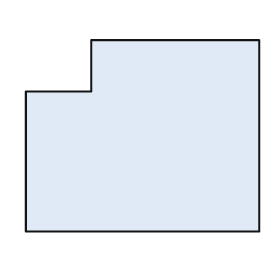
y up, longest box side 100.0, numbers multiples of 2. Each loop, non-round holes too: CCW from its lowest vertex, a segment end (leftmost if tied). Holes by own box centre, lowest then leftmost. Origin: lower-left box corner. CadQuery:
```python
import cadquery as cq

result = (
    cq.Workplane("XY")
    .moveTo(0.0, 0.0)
    .lineTo(100.0, 0.0)
    .lineTo(100.0, 82.0)
    .lineTo(28.0, 82.0)
    .lineTo(28.0, 60.0)
    .lineTo(0.0, 60.0)
    .close()
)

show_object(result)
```